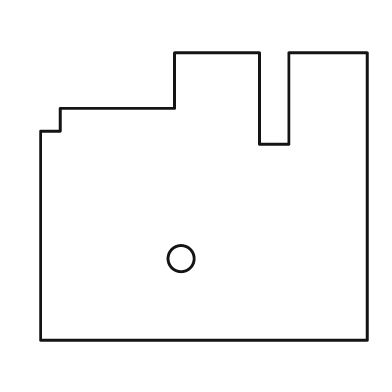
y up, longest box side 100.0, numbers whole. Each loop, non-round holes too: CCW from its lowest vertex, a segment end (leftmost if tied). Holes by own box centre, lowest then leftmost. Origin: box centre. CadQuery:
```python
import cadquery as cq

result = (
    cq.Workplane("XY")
    .moveTo(-50.0, -44.0)
    .lineTo(50.0, -44.0)
    .lineTo(50.0, 44.0)
    .lineTo(26.0, 44.0)
    .lineTo(26.0, 16.0)
    .lineTo(17.0, 16.0)
    .lineTo(17.0, 44.0)
    .lineTo(-9.0, 44.0)
    .lineTo(-9.0, 27.0)
    .lineTo(-44.0, 27.0)
    .lineTo(-44.0, 20.0)
    .lineTo(-50.0, 20.0)
    .close()
    .moveTo(-7.0, -19.0)
    .circle(4.0)
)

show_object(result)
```